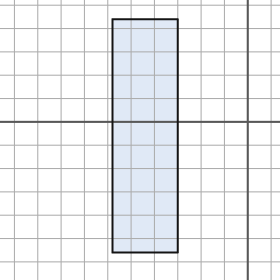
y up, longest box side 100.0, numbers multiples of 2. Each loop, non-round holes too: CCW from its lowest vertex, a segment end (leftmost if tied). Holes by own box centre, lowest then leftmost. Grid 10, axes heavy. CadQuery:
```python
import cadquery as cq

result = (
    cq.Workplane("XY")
    .moveTo(-58.0, -56.0)
    .lineTo(-30.0, -56.0)
    .lineTo(-30.0, 44.0)
    .lineTo(-58.0, 44.0)
    .close()
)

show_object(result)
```